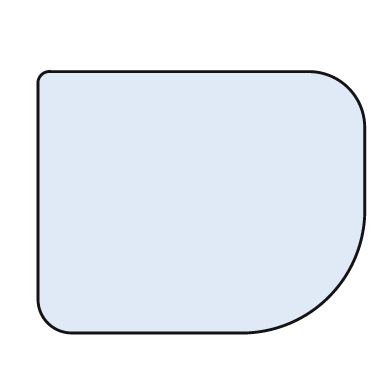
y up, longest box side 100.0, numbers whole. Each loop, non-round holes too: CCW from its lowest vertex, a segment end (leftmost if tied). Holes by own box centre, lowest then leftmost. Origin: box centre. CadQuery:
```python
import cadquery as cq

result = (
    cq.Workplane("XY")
    .moveTo(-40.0, -40.0)
    .lineTo(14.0, -40.0)
    .threePointArc((39.0, -29.0), (50.0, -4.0))
    .lineTo(50.0, 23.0)
    .threePointArc((45.0, 35.0), (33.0, 40.0))
    .lineTo(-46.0, 40.0)
    .threePointArc((-49.0, 39.0), (-50.0, 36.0))
    .lineTo(-50.0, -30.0)
    .threePointArc((-47.0, -37.0), (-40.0, -40.0))
    .close()
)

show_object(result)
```